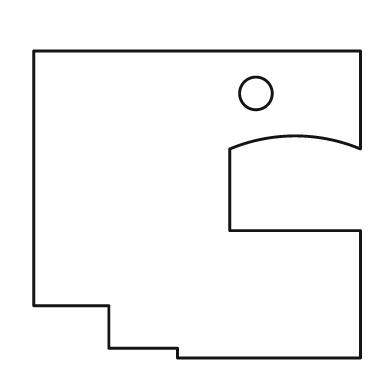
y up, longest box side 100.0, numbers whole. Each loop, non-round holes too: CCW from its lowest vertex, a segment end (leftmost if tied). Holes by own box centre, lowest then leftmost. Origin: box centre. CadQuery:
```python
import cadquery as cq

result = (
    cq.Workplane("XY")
    .moveTo(-6.0, -47.0)
    .lineTo(50.0, -47.0)
    .lineTo(50.0, -8.0)
    .lineTo(10.0, -8.0)
    .lineTo(10.0, 17.0)
    .threePointArc((30.0, 21.0), (50.0, 17.0))
    .lineTo(50.0, 47.0)
    .lineTo(-50.0, 47.0)
    .lineTo(-50.0, -31.0)
    .lineTo(-27.0, -31.0)
    .lineTo(-27.0, -44.0)
    .lineTo(-6.0, -44.0)
    .close()
    .moveTo(18.0, 34.0)
    .circle(5.0)
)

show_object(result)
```